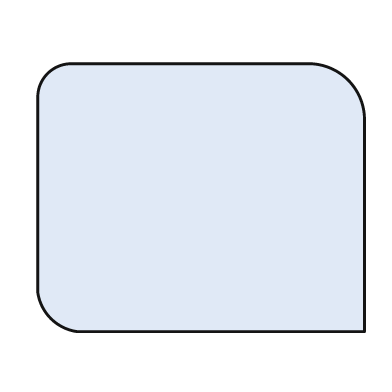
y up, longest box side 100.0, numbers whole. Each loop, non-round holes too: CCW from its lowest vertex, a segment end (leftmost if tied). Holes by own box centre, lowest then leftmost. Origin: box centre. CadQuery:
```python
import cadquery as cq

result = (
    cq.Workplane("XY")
    .moveTo(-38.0, -41.0)
    .lineTo(50.0, -41.0)
    .lineTo(50.0, 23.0)
    .threePointArc((45.0, 36.0), (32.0, 41.0))
    .lineTo(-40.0, 41.0)
    .threePointArc((-47.0, 38.0), (-50.0, 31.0))
    .lineTo(-50.0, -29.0)
    .threePointArc((-46.0, -37.0), (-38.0, -41.0))
    .close()
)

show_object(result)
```